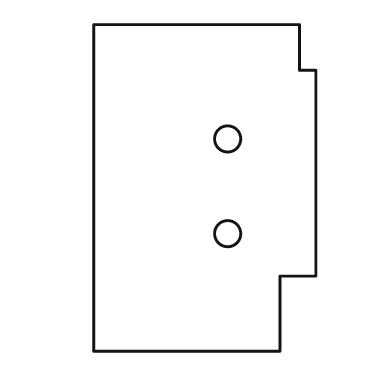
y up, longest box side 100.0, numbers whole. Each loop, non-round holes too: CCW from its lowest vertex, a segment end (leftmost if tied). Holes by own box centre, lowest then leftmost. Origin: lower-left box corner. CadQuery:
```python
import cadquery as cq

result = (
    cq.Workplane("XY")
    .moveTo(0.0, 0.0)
    .lineTo(57.0, 0.0)
    .lineTo(57.0, 23.0)
    .lineTo(68.0, 23.0)
    .lineTo(68.0, 86.0)
    .lineTo(63.0, 86.0)
    .lineTo(63.0, 100.0)
    .lineTo(0.0, 100.0)
    .close()
    .moveTo(41.0, 36.0)
    .circle(4.0)
    .moveTo(41.0, 65.0)
    .circle(4.0)
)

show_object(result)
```